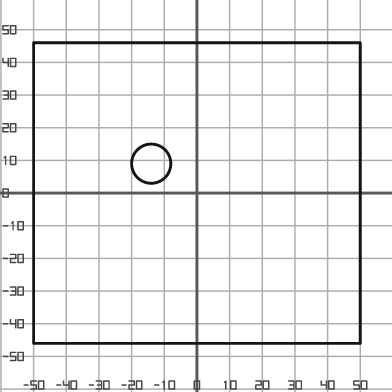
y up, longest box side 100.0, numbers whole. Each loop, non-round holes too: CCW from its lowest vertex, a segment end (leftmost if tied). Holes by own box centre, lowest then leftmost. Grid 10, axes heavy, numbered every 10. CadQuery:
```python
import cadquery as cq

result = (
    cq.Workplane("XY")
    .moveTo(-50.0, -46.0)
    .lineTo(50.0, -46.0)
    .lineTo(50.0, 46.0)
    .lineTo(-50.0, 46.0)
    .close()
    .moveTo(-14.0, 9.0)
    .circle(6.0)
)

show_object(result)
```